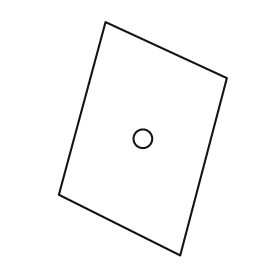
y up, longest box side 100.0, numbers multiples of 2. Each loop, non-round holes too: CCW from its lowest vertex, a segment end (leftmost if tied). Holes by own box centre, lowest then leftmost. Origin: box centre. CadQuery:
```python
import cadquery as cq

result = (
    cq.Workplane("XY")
    .moveTo(16.0, -50.0)
    .lineTo(36.0, 26.0)
    .lineTo(-16.0, 50.0)
    .lineTo(-36.0, -24.0)
    .close()
    .moveTo(0.0, 0.0)
    .circle(4.0)
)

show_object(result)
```